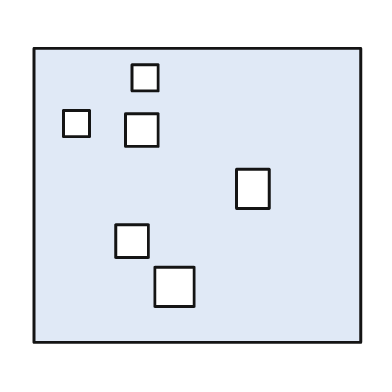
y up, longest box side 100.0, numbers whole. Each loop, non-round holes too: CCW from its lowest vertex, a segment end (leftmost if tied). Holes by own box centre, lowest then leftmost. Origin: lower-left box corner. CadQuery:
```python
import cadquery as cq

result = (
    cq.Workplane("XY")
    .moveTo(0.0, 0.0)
    .lineTo(100.0, 0.0)
    .lineTo(100.0, 90.0)
    .lineTo(0.0, 90.0)
    .close()
    .moveTo(37.0, 11.0)
    .lineTo(49.0, 11.0)
    .lineTo(49.0, 23.0)
    .lineTo(37.0, 23.0)
    .close()
    .moveTo(25.0, 26.0)
    .lineTo(35.0, 26.0)
    .lineTo(35.0, 36.0)
    .lineTo(25.0, 36.0)
    .close()
    .moveTo(62.0, 41.0)
    .lineTo(72.0, 41.0)
    .lineTo(72.0, 53.0)
    .lineTo(62.0, 53.0)
    .close()
    .moveTo(28.0, 60.0)
    .lineTo(38.0, 60.0)
    .lineTo(38.0, 70.0)
    .lineTo(28.0, 70.0)
    .close()
    .moveTo(9.0, 63.0)
    .lineTo(17.0, 63.0)
    .lineTo(17.0, 71.0)
    .lineTo(9.0, 71.0)
    .close()
    .moveTo(30.0, 77.0)
    .lineTo(38.0, 77.0)
    .lineTo(38.0, 85.0)
    .lineTo(30.0, 85.0)
    .close()
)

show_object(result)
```